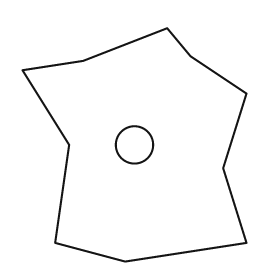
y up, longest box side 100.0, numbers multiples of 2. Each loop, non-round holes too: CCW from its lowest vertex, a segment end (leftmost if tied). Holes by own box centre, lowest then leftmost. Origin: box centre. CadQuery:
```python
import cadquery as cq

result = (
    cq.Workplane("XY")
    .moveTo(-4.0, -50.0)
    .lineTo(48.0, -42.0)
    .lineTo(38.0, -10.0)
    .lineTo(48.0, 22.0)
    .lineTo(24.0, 38.0)
    .lineTo(14.0, 50.0)
    .lineTo(-22.0, 36.0)
    .lineTo(-48.0, 32.0)
    .lineTo(-28.0, 0.0)
    .lineTo(-34.0, -42.0)
    .close()
    .moveTo(0.0, 0.0)
    .circle(8.0)
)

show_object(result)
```